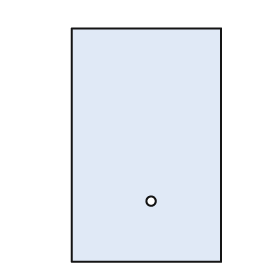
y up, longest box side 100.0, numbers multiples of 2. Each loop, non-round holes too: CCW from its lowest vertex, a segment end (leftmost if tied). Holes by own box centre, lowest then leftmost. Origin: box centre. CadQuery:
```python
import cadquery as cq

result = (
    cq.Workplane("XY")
    .moveTo(-32.0, -50.0)
    .lineTo(32.0, -50.0)
    .lineTo(32.0, 50.0)
    .lineTo(-32.0, 50.0)
    .close()
    .moveTo(2.0, -24.0)
    .circle(2.0)
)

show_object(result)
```